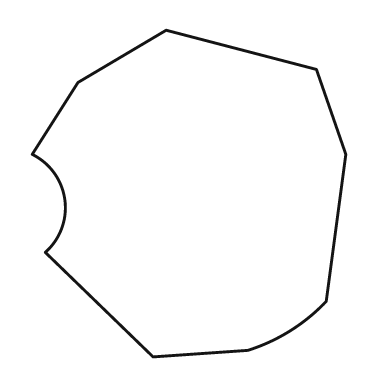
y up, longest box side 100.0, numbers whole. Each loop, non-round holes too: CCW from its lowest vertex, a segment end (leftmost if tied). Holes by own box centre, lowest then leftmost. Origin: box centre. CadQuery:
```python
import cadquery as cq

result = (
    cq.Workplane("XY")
    .moveTo(-11.0, -50.0)
    .lineTo(18.0, -48.0)
    .threePointArc((31.0, -42.0), (42.0, -33.0))
    .lineTo(48.0, 12.0)
    .lineTo(39.0, 38.0)
    .lineTo(-7.0, 50.0)
    .lineTo(-34.0, 34.0)
    .lineTo(-48.0, 12.0)
    .threePointArc((-38.0, -2.0), (-44.0, -18.0))
    .close()
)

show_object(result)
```